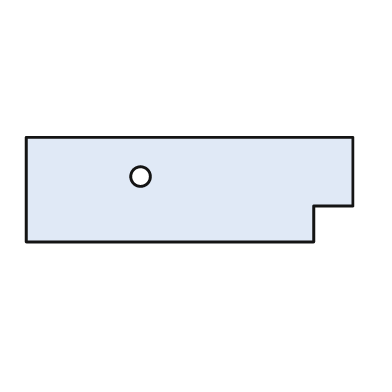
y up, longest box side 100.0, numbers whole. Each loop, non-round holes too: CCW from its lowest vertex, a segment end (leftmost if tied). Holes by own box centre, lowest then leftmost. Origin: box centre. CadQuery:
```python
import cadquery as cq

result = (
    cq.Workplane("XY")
    .moveTo(-50.0, -16.0)
    .lineTo(38.0, -16.0)
    .lineTo(38.0, -5.0)
    .lineTo(50.0, -5.0)
    .lineTo(50.0, 16.0)
    .lineTo(-50.0, 16.0)
    .close()
    .moveTo(-15.0, 4.0)
    .circle(3.0)
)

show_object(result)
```